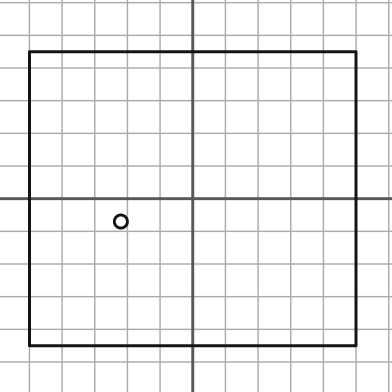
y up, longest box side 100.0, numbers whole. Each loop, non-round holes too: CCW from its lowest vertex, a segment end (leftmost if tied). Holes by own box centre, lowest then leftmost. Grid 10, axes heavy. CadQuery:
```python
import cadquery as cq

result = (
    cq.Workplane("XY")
    .moveTo(-50.0, -45.0)
    .lineTo(50.0, -45.0)
    .lineTo(50.0, 45.0)
    .lineTo(-50.0, 45.0)
    .close()
    .moveTo(-22.0, -7.0)
    .circle(2.0)
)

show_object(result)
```